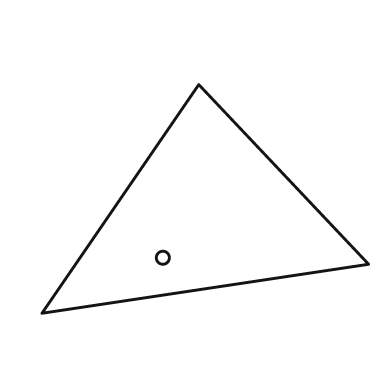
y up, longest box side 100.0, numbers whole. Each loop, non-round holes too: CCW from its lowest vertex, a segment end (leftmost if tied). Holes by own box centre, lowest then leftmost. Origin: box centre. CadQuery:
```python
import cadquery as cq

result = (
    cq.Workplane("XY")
    .moveTo(-50.0, -35.0)
    .lineTo(50.0, -20.0)
    .lineTo(-2.0, 35.0)
    .close()
    .moveTo(-13.0, -18.0)
    .circle(2.0)
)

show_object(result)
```